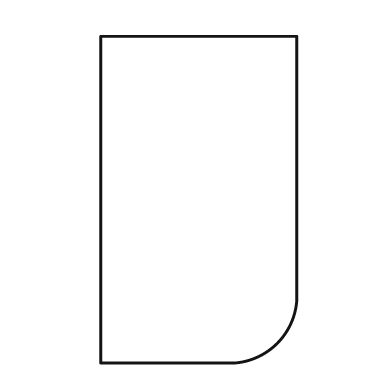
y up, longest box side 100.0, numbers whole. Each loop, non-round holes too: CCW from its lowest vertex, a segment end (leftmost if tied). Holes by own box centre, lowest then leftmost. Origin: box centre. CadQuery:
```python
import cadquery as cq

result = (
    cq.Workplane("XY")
    .moveTo(-30.0, -50.0)
    .lineTo(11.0, -50.0)
    .threePointArc((24.0, -44.0), (30.0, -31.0))
    .lineTo(30.0, 50.0)
    .lineTo(-30.0, 50.0)
    .close()
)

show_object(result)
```